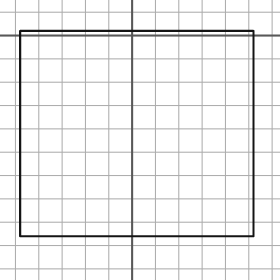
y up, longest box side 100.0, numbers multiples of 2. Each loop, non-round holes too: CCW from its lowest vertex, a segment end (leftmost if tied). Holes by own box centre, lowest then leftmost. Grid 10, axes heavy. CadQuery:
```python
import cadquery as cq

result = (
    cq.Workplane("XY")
    .moveTo(-48.0, -86.0)
    .lineTo(52.0, -86.0)
    .lineTo(52.0, 2.0)
    .lineTo(-48.0, 2.0)
    .close()
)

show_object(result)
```